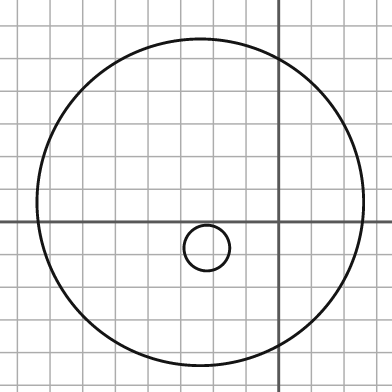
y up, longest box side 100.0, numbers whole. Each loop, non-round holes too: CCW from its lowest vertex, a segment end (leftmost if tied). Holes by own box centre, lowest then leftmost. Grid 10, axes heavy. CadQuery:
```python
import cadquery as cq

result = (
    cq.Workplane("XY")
    .moveTo(-24.0, 6.0)
    .circle(50.0)
    .moveTo(-22.0, -8.0)
    .circle(7.0)
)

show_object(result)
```